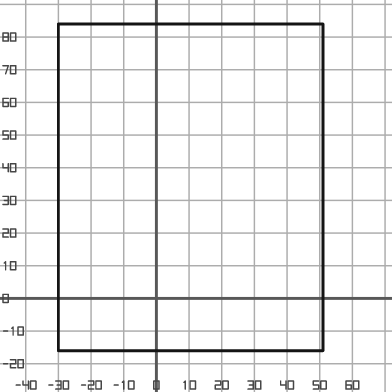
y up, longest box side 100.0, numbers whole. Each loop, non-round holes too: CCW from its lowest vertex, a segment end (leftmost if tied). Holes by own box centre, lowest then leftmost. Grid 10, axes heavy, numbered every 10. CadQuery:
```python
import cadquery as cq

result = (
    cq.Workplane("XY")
    .moveTo(-30.0, -16.0)
    .lineTo(51.0, -16.0)
    .lineTo(51.0, 84.0)
    .lineTo(-30.0, 84.0)
    .close()
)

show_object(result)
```